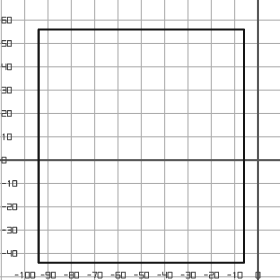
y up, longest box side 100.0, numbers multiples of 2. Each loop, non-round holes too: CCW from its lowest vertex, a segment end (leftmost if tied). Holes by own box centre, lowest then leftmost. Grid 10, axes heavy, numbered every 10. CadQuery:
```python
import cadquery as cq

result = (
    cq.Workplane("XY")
    .moveTo(-94.0, -44.0)
    .lineTo(-6.0, -44.0)
    .lineTo(-6.0, 56.0)
    .lineTo(-94.0, 56.0)
    .close()
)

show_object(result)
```